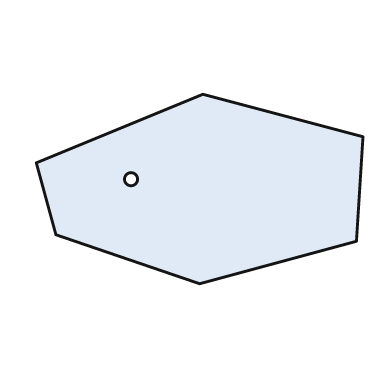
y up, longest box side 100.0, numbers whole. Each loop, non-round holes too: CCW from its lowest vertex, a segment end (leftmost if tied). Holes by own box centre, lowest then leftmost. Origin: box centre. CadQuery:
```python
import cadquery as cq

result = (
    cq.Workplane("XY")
    .moveTo(0.0, -29.0)
    .lineTo(48.0, -16.0)
    .lineTo(50.0, 16.0)
    .lineTo(1.0, 29.0)
    .lineTo(-50.0, 8.0)
    .lineTo(-44.0, -14.0)
    .close()
    .moveTo(-21.0, 3.0)
    .circle(2.0)
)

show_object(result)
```